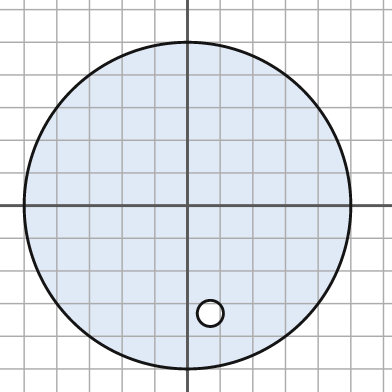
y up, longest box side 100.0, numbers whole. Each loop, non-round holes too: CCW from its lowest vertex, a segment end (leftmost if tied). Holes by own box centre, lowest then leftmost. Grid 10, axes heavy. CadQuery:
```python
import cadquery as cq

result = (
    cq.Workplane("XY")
    .moveTo(0.0, 0.0)
    .circle(50.0)
    .moveTo(7.0, -33.0)
    .circle(4.0)
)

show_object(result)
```